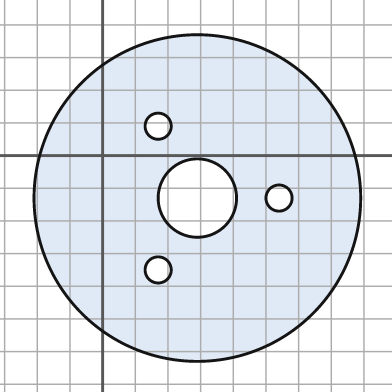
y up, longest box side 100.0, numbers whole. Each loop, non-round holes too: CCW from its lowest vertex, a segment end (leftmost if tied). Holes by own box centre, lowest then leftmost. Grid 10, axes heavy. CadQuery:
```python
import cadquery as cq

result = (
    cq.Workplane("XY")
    .moveTo(29.0, -13.0)
    .circle(50.0)
    .moveTo(17.0, -35.0)
    .circle(4.0)
    .moveTo(29.0, -13.0)
    .circle(12.0)
    .moveTo(54.0, -13.0)
    .circle(4.0)
    .moveTo(17.0, 9.0)
    .circle(4.0)
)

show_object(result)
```